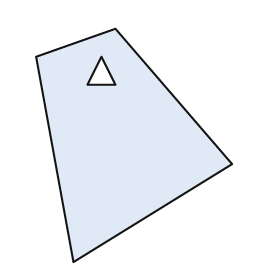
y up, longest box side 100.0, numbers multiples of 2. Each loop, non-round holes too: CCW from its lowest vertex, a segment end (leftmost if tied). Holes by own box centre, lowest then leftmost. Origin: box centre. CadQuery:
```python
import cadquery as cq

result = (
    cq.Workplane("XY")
    .moveTo(-26.0, -50.0)
    .lineTo(42.0, -8.0)
    .lineTo(-8.0, 50.0)
    .lineTo(-42.0, 38.0)
    .close()
    .moveTo(-20.0, 26.0)
    .lineTo(-8.0, 26.0)
    .lineTo(-14.0, 38.0)
    .close()
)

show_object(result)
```